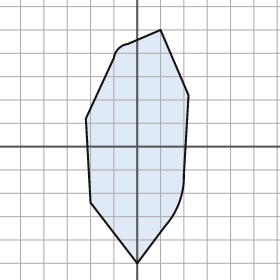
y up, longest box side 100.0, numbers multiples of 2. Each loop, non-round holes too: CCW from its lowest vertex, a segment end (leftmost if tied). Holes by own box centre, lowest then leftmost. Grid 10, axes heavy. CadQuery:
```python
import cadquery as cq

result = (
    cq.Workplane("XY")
    .moveTo(0.0, -50.0)
    .lineTo(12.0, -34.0)
    .threePointArc((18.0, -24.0), (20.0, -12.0))
    .lineTo(22.0, 22.0)
    .lineTo(10.0, 50.0)
    .lineTo(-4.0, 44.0)
    .threePointArc((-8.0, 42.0), (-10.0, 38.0))
    .lineTo(-22.0, 12.0)
    .lineTo(-20.0, -24.0)
    .close()
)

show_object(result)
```